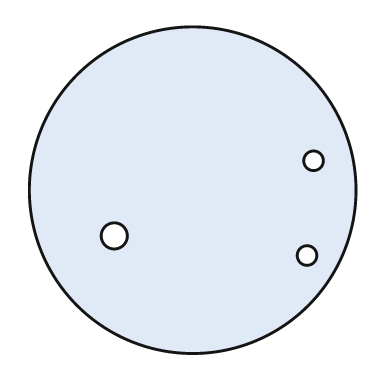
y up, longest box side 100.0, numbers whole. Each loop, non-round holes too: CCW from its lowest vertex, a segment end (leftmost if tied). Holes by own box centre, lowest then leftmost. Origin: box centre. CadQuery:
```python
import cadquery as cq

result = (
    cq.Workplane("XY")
    .moveTo(0.0, 0.0)
    .circle(50.0)
    .moveTo(35.0, -20.0)
    .circle(3.0)
    .moveTo(-24.0, -14.0)
    .circle(4.0)
    .moveTo(37.0, 9.0)
    .circle(3.0)
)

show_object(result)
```